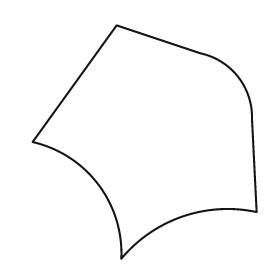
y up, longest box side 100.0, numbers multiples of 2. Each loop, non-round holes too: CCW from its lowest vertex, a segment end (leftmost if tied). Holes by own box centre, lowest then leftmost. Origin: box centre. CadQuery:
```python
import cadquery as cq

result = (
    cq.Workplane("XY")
    .moveTo(-10.0, -50.0)
    .threePointArc((16.0, -32.0), (48.0, -30.0))
    .lineTo(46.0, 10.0)
    .threePointArc((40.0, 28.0), (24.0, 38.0))
    .lineTo(-12.0, 50.0)
    .lineTo(-48.0, 0.0)
    .threePointArc((-20.0, -18.0), (-10.0, -50.0))
    .close()
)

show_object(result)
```